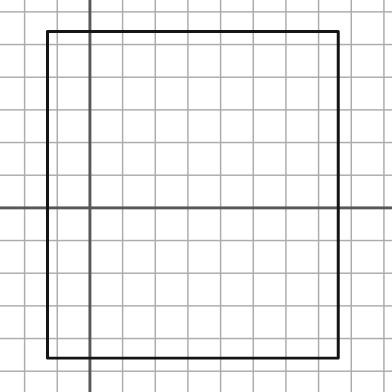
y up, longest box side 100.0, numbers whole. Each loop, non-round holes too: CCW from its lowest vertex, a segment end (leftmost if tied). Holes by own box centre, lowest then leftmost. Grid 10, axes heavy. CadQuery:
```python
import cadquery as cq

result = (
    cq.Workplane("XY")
    .moveTo(-13.0, -46.0)
    .lineTo(76.0, -46.0)
    .lineTo(76.0, 54.0)
    .lineTo(-13.0, 54.0)
    .close()
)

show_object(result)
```